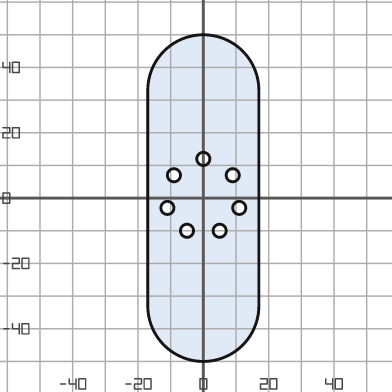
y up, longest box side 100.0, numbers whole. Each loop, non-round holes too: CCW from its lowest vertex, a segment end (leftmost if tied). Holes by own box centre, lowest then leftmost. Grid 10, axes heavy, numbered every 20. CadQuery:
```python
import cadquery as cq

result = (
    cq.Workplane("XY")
    .moveTo(-17.0, -33.0)
    .threePointArc((0.0, -50.0), (17.0, -33.0))
    .lineTo(17.0, 33.0)
    .threePointArc((0.0, 50.0), (-17.0, 33.0))
    .close()
    .moveTo(-5.0, -10.0)
    .circle(2.0)
    .moveTo(5.0, -10.0)
    .circle(2.0)
    .moveTo(-11.0, -3.0)
    .circle(2.0)
    .moveTo(11.0, -3.0)
    .circle(2.0)
    .moveTo(-9.0, 7.0)
    .circle(2.0)
    .moveTo(9.0, 7.0)
    .circle(2.0)
    .moveTo(0.0, 12.0)
    .circle(2.0)
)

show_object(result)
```